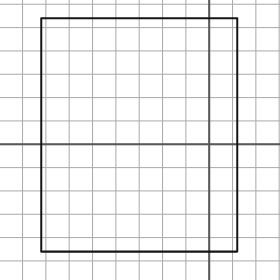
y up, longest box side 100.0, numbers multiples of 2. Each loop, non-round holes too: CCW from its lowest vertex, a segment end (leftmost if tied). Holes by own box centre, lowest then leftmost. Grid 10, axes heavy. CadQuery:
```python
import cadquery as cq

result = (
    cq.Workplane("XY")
    .moveTo(-72.0, -46.0)
    .lineTo(12.0, -46.0)
    .lineTo(12.0, 54.0)
    .lineTo(-72.0, 54.0)
    .close()
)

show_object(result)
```